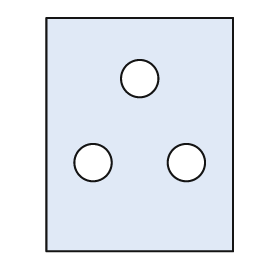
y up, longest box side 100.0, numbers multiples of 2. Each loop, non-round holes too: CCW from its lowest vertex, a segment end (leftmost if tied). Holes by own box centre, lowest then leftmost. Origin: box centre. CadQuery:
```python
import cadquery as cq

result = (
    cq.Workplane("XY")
    .moveTo(-40.0, -50.0)
    .lineTo(40.0, -50.0)
    .lineTo(40.0, 50.0)
    .lineTo(-40.0, 50.0)
    .close()
    .moveTo(-20.0, -12.0)
    .circle(8.0)
    .moveTo(20.0, -12.0)
    .circle(8.0)
    .moveTo(0.0, 24.0)
    .circle(8.0)
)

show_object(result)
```